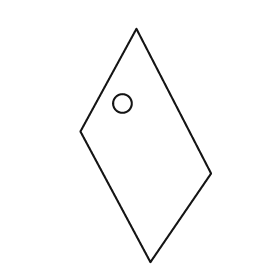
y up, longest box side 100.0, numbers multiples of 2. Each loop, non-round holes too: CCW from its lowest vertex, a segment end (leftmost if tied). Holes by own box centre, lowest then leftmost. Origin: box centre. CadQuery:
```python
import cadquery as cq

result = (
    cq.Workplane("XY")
    .moveTo(2.0, -50.0)
    .lineTo(28.0, -12.0)
    .lineTo(-4.0, 50.0)
    .lineTo(-28.0, 6.0)
    .close()
    .moveTo(-10.0, 18.0)
    .circle(4.0)
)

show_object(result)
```